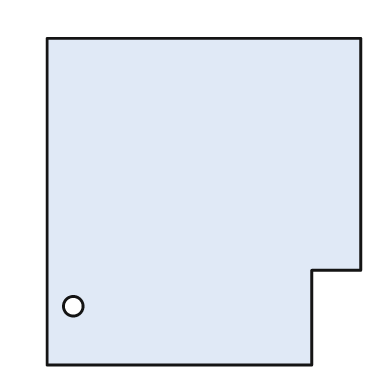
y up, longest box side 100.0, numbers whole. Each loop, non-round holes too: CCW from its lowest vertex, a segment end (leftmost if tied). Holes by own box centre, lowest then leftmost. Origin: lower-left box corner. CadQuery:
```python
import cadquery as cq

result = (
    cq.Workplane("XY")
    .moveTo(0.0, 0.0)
    .lineTo(81.0, 0.0)
    .lineTo(81.0, 29.0)
    .lineTo(96.0, 29.0)
    .lineTo(96.0, 100.0)
    .lineTo(0.0, 100.0)
    .close()
    .moveTo(8.0, 18.0)
    .circle(3.0)
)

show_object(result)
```